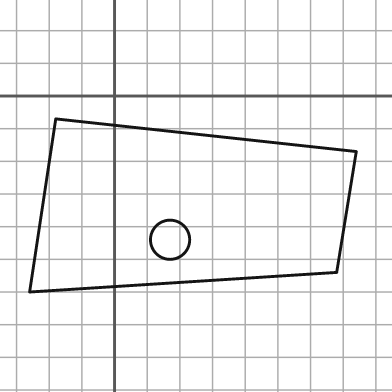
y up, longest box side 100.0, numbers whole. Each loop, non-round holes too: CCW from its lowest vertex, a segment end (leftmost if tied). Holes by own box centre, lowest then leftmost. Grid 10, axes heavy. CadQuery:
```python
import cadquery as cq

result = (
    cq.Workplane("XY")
    .moveTo(-26.0, -60.0)
    .lineTo(68.0, -54.0)
    .lineTo(74.0, -17.0)
    .lineTo(-18.0, -7.0)
    .close()
    .moveTo(17.0, -44.0)
    .circle(6.0)
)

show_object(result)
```